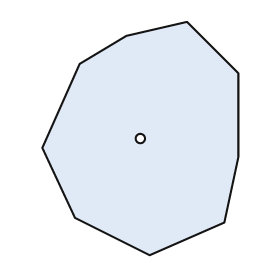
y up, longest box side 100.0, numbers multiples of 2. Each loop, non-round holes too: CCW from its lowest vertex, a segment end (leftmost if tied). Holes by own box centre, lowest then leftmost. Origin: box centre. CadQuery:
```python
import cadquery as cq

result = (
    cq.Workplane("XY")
    .moveTo(4.0, -50.0)
    .lineTo(36.0, -36.0)
    .lineTo(42.0, -8.0)
    .lineTo(42.0, 28.0)
    .lineTo(20.0, 50.0)
    .lineTo(-6.0, 44.0)
    .lineTo(-26.0, 32.0)
    .lineTo(-42.0, -4.0)
    .lineTo(-28.0, -34.0)
    .close()
    .moveTo(0.0, 0.0)
    .circle(2.0)
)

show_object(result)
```